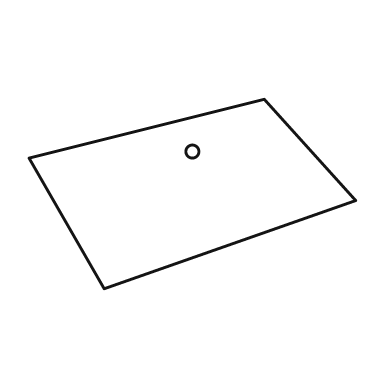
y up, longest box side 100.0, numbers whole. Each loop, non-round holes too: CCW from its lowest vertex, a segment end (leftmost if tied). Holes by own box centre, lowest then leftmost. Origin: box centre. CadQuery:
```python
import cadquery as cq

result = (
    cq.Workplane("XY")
    .moveTo(-27.0, -29.0)
    .lineTo(50.0, -2.0)
    .lineTo(22.0, 29.0)
    .lineTo(-50.0, 11.0)
    .close()
    .moveTo(0.0, 13.0)
    .circle(2.0)
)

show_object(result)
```